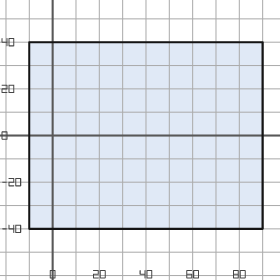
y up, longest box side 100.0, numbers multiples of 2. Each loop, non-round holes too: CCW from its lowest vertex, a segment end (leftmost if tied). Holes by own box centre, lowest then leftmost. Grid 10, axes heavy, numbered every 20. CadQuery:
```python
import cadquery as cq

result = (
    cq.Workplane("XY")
    .moveTo(-10.0, -40.0)
    .lineTo(90.0, -40.0)
    .lineTo(90.0, 40.0)
    .lineTo(-10.0, 40.0)
    .close()
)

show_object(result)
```